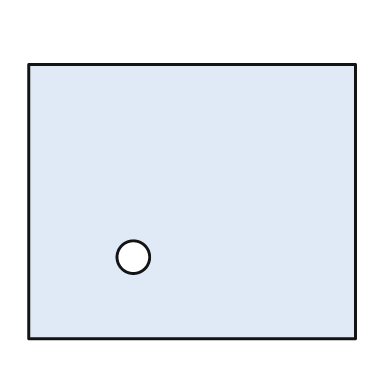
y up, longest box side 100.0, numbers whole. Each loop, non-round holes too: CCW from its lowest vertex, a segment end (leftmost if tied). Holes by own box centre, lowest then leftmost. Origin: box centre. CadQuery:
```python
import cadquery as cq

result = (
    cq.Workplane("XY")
    .moveTo(-50.0, -42.0)
    .lineTo(50.0, -42.0)
    .lineTo(50.0, 42.0)
    .lineTo(-50.0, 42.0)
    .close()
    .moveTo(-18.0, -17.0)
    .circle(5.0)
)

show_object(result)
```